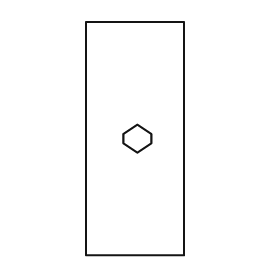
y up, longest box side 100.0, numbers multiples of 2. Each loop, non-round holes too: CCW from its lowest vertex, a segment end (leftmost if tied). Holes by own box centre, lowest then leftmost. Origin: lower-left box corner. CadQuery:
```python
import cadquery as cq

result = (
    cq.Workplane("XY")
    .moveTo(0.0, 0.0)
    .lineTo(42.0, 0.0)
    .lineTo(42.0, 100.0)
    .lineTo(0.0, 100.0)
    .close()
    .moveTo(22.0, 44.0)
    .lineTo(28.0, 48.0)
    .lineTo(28.0, 52.0)
    .lineTo(22.0, 56.0)
    .lineTo(16.0, 52.0)
    .lineTo(16.0, 48.0)
    .close()
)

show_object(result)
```